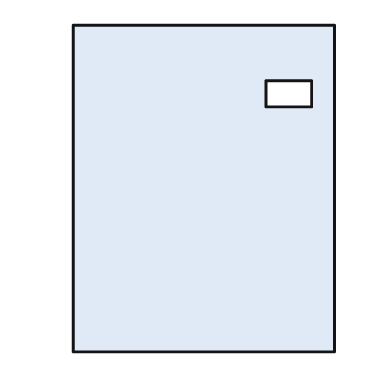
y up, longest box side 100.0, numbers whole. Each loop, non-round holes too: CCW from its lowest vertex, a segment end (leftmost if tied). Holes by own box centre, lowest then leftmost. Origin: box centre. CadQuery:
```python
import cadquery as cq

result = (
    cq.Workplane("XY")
    .moveTo(-40.0, -50.0)
    .lineTo(40.0, -50.0)
    .lineTo(40.0, 50.0)
    .lineTo(-40.0, 50.0)
    .close()
    .moveTo(19.0, 25.0)
    .lineTo(33.0, 25.0)
    .lineTo(33.0, 33.0)
    .lineTo(19.0, 33.0)
    .close()
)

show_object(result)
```